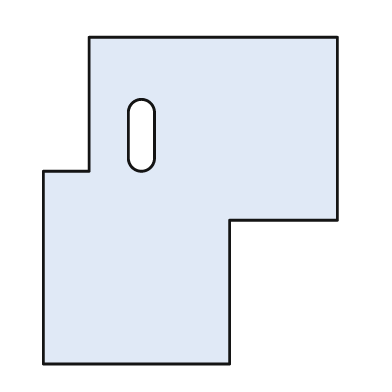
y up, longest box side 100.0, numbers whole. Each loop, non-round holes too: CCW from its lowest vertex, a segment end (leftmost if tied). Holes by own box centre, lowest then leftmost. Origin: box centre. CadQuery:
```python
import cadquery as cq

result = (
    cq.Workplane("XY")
    .moveTo(-45.0, -50.0)
    .lineTo(12.0, -50.0)
    .lineTo(12.0, -6.0)
    .lineTo(45.0, -6.0)
    .lineTo(45.0, 50.0)
    .lineTo(-31.0, 50.0)
    .lineTo(-31.0, 9.0)
    .lineTo(-45.0, 9.0)
    .close()
    .moveTo(-19.0, 13.0)
    .threePointArc((-15.0, 9.0), (-11.0, 13.0))
    .lineTo(-11.0, 27.0)
    .threePointArc((-15.0, 31.0), (-19.0, 27.0))
    .close()
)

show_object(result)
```